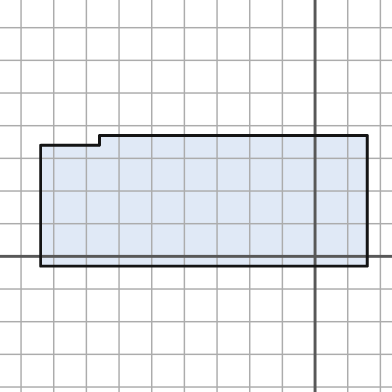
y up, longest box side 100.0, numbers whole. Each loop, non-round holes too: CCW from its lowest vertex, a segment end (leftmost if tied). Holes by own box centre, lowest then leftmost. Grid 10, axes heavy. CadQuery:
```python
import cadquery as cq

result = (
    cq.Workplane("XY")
    .moveTo(-84.0, -3.0)
    .lineTo(16.0, -3.0)
    .lineTo(16.0, 37.0)
    .lineTo(-66.0, 37.0)
    .lineTo(-66.0, 34.0)
    .lineTo(-84.0, 34.0)
    .close()
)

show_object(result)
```